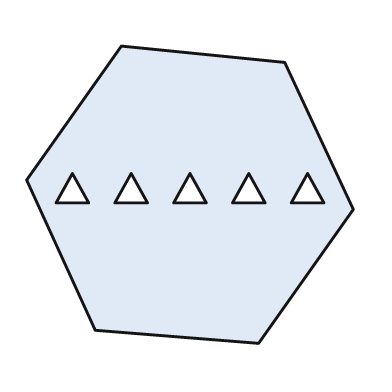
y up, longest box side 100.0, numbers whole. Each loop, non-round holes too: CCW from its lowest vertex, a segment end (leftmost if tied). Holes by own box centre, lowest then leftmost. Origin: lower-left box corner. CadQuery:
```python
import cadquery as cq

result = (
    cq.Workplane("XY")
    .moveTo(71.0, 0.0)
    .lineTo(100.0, 41.0)
    .lineTo(79.0, 86.0)
    .lineTo(29.0, 91.0)
    .lineTo(0.0, 50.0)
    .lineTo(21.0, 4.0)
    .close()
    .moveTo(9.0, 43.0)
    .lineTo(19.0, 43.0)
    .lineTo(14.0, 52.0)
    .close()
    .moveTo(27.0, 43.0)
    .lineTo(37.0, 43.0)
    .lineTo(32.0, 52.0)
    .close()
    .moveTo(45.0, 43.0)
    .lineTo(55.0, 43.0)
    .lineTo(50.0, 52.0)
    .close()
    .moveTo(63.0, 43.0)
    .lineTo(73.0, 43.0)
    .lineTo(68.0, 52.0)
    .close()
    .moveTo(81.0, 43.0)
    .lineTo(91.0, 43.0)
    .lineTo(86.0, 52.0)
    .close()
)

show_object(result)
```